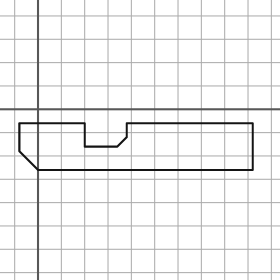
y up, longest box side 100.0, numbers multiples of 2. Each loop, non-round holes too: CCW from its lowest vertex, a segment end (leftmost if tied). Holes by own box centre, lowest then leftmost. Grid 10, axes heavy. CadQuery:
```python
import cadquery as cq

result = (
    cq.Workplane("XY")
    .moveTo(0.0, -26.0)
    .lineTo(92.0, -26.0)
    .lineTo(92.0, -6.0)
    .lineTo(38.0, -6.0)
    .lineTo(38.0, -12.0)
    .lineTo(34.0, -16.0)
    .lineTo(20.0, -16.0)
    .lineTo(20.0, -6.0)
    .lineTo(-8.0, -6.0)
    .lineTo(-8.0, -18.0)
    .close()
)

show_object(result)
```